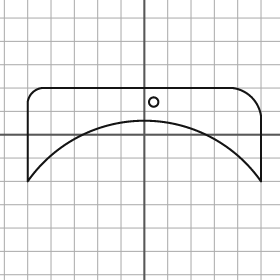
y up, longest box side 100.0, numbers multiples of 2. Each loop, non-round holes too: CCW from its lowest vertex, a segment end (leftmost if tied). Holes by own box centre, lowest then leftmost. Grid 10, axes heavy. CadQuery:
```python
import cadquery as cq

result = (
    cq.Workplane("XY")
    .moveTo(-50.0, -20.0)
    .threePointArc((0.0, 6.0), (50.0, -20.0))
    .lineTo(50.0, 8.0)
    .threePointArc((46.0, 16.0), (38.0, 20.0))
    .lineTo(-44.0, 20.0)
    .threePointArc((-48.0, 18.0), (-50.0, 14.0))
    .close()
    .moveTo(4.0, 14.0)
    .circle(2.0)
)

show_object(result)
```